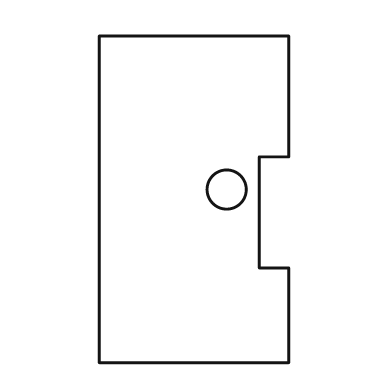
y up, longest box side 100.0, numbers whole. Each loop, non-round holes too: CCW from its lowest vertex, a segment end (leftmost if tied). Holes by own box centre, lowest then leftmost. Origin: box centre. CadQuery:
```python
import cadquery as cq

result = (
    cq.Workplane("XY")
    .moveTo(-29.0, -50.0)
    .lineTo(29.0, -50.0)
    .lineTo(29.0, -21.0)
    .lineTo(20.0, -21.0)
    .lineTo(20.0, 13.0)
    .lineTo(29.0, 13.0)
    .lineTo(29.0, 50.0)
    .lineTo(-29.0, 50.0)
    .close()
    .moveTo(10.0, 3.0)
    .circle(6.0)
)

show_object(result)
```